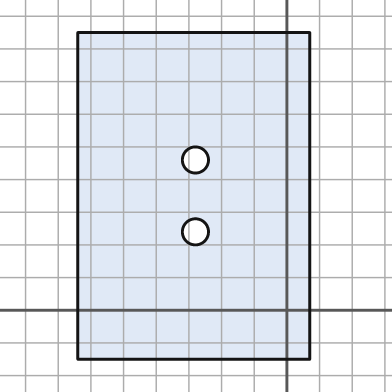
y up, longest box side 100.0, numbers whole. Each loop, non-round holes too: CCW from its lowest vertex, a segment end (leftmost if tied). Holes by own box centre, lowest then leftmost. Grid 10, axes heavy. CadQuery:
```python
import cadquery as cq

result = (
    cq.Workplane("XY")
    .moveTo(-64.0, -15.0)
    .lineTo(7.0, -15.0)
    .lineTo(7.0, 85.0)
    .lineTo(-64.0, 85.0)
    .close()
    .moveTo(-28.0, 24.0)
    .circle(4.0)
    .moveTo(-28.0, 46.0)
    .circle(4.0)
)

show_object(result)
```